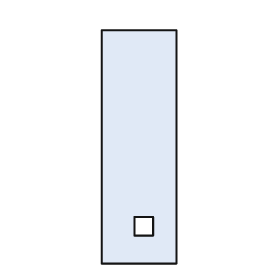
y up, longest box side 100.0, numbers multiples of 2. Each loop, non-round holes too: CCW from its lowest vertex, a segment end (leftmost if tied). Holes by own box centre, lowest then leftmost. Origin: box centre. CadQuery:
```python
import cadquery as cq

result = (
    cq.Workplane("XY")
    .moveTo(-16.0, -50.0)
    .lineTo(16.0, -50.0)
    .lineTo(16.0, 50.0)
    .lineTo(-16.0, 50.0)
    .close()
    .moveTo(-2.0, -38.0)
    .lineTo(6.0, -38.0)
    .lineTo(6.0, -30.0)
    .lineTo(-2.0, -30.0)
    .close()
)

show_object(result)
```